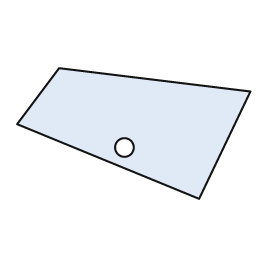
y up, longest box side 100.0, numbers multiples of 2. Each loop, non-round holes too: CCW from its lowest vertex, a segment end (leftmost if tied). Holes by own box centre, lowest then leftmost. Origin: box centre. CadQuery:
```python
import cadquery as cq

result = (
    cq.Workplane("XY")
    .moveTo(28.0, -28.0)
    .lineTo(50.0, 18.0)
    .lineTo(-32.0, 28.0)
    .lineTo(-50.0, 4.0)
    .close()
    .moveTo(-4.0, -6.0)
    .circle(4.0)
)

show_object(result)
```